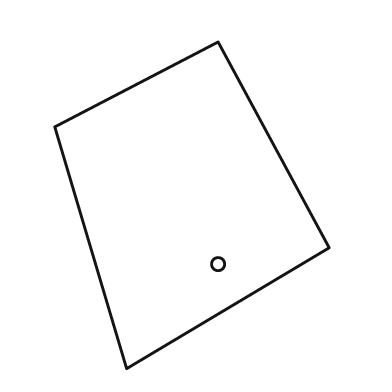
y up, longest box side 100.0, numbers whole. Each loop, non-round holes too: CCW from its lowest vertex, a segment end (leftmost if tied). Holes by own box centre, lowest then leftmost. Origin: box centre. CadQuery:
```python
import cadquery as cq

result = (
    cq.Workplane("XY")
    .moveTo(-20.0, -50.0)
    .lineTo(42.0, -13.0)
    .lineTo(8.0, 50.0)
    .lineTo(-42.0, 24.0)
    .close()
    .moveTo(8.0, -18.0)
    .circle(2.0)
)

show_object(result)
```